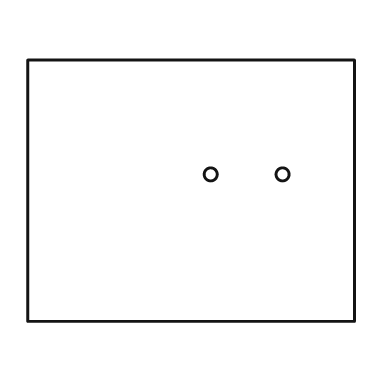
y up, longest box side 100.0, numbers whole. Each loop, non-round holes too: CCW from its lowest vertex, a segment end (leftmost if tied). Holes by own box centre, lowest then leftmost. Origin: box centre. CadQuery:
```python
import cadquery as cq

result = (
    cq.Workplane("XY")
    .moveTo(-50.0, -40.0)
    .lineTo(50.0, -40.0)
    .lineTo(50.0, 40.0)
    .lineTo(-50.0, 40.0)
    .close()
    .moveTo(6.0, 5.0)
    .circle(2.0)
    .moveTo(28.0, 5.0)
    .circle(2.0)
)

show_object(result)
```